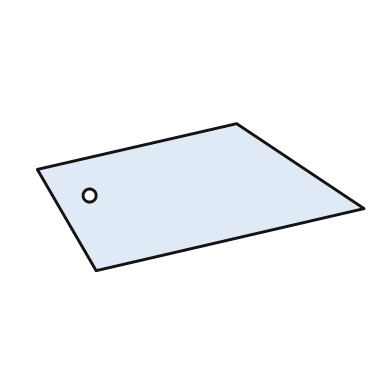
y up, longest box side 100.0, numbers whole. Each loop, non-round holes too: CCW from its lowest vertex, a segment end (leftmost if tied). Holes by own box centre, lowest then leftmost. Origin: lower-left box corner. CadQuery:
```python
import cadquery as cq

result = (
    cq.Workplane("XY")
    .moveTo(18.0, 0.0)
    .lineTo(100.0, 19.0)
    .lineTo(61.0, 45.0)
    .lineTo(0.0, 31.0)
    .close()
    .moveTo(16.0, 23.0)
    .circle(2.0)
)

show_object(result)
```